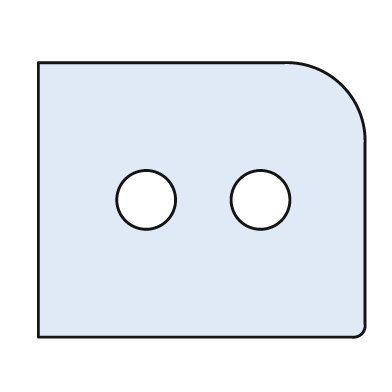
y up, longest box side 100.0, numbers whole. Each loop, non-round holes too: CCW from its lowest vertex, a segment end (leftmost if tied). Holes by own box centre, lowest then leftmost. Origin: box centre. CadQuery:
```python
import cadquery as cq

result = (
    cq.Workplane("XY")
    .moveTo(-50.0, -42.0)
    .lineTo(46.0, -42.0)
    .threePointArc((49.0, -41.0), (50.0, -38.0))
    .lineTo(50.0, 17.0)
    .threePointArc((43.0, 35.0), (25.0, 42.0))
    .lineTo(-50.0, 42.0)
    .close()
    .moveTo(-17.0, 0.0)
    .circle(9.0)
    .moveTo(18.0, 0.0)
    .circle(9.0)
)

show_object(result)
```